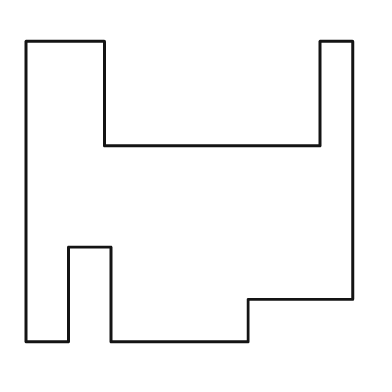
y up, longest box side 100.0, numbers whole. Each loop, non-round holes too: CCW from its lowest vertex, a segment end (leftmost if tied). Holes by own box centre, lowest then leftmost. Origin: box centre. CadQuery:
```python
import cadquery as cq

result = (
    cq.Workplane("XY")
    .moveTo(-50.0, -46.0)
    .lineTo(-37.0, -46.0)
    .lineTo(-37.0, -17.0)
    .lineTo(-24.0, -17.0)
    .lineTo(-24.0, -46.0)
    .lineTo(18.0, -46.0)
    .lineTo(18.0, -33.0)
    .lineTo(50.0, -33.0)
    .lineTo(50.0, 46.0)
    .lineTo(40.0, 46.0)
    .lineTo(40.0, 14.0)
    .lineTo(-26.0, 14.0)
    .lineTo(-26.0, 46.0)
    .lineTo(-50.0, 46.0)
    .close()
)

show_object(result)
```